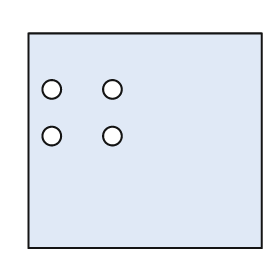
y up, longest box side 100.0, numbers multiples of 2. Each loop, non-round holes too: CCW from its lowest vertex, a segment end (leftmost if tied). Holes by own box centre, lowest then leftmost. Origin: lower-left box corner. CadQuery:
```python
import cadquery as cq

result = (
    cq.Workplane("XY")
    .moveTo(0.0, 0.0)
    .lineTo(100.0, 0.0)
    .lineTo(100.0, 92.0)
    .lineTo(0.0, 92.0)
    .close()
    .moveTo(10.0, 48.0)
    .circle(4.0)
    .moveTo(36.0, 48.0)
    .circle(4.0)
    .moveTo(10.0, 68.0)
    .circle(4.0)
    .moveTo(36.0, 68.0)
    .circle(4.0)
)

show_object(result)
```